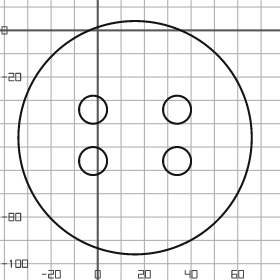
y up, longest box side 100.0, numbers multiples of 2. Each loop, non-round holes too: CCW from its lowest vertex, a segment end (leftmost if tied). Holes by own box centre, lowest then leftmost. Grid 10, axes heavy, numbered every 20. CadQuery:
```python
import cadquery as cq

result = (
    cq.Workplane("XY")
    .moveTo(16.0, -46.0)
    .circle(50.0)
    .moveTo(-2.0, -56.0)
    .circle(6.0)
    .moveTo(34.0, -56.0)
    .circle(6.0)
    .moveTo(-2.0, -34.0)
    .circle(6.0)
    .moveTo(34.0, -34.0)
    .circle(6.0)
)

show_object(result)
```